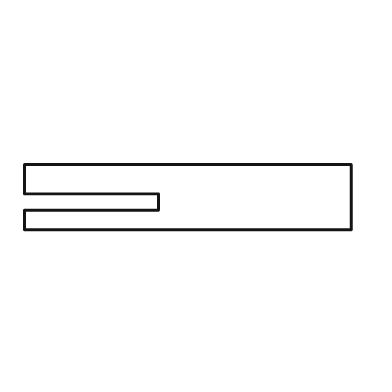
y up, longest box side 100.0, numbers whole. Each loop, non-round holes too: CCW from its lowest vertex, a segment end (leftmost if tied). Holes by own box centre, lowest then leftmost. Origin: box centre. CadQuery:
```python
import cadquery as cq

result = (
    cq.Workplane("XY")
    .moveTo(-50.0, -10.0)
    .lineTo(50.0, -10.0)
    .lineTo(50.0, 10.0)
    .lineTo(-50.0, 10.0)
    .lineTo(-50.0, 1.0)
    .lineTo(-9.0, 1.0)
    .lineTo(-9.0, -4.0)
    .lineTo(-50.0, -4.0)
    .close()
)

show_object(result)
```